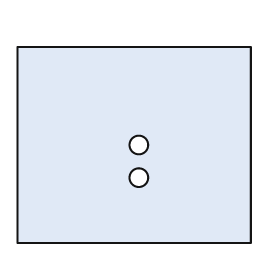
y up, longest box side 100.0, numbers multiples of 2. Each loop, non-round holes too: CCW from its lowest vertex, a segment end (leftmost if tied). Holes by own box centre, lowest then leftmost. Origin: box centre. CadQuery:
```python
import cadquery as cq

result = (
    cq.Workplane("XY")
    .moveTo(-50.0, -42.0)
    .lineTo(50.0, -42.0)
    .lineTo(50.0, 42.0)
    .lineTo(-50.0, 42.0)
    .close()
    .moveTo(2.0, -14.0)
    .circle(4.0)
    .moveTo(2.0, 0.0)
    .circle(4.0)
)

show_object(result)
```